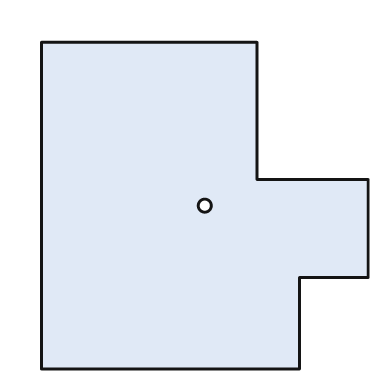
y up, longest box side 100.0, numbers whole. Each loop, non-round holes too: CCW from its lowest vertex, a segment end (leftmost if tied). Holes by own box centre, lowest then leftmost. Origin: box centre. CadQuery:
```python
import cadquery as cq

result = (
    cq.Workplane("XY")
    .moveTo(-50.0, -50.0)
    .lineTo(29.0, -50.0)
    .lineTo(29.0, -22.0)
    .lineTo(50.0, -22.0)
    .lineTo(50.0, 8.0)
    .lineTo(16.0, 8.0)
    .lineTo(16.0, 50.0)
    .lineTo(-50.0, 50.0)
    .close()
    .moveTo(0.0, 0.0)
    .circle(2.0)
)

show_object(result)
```